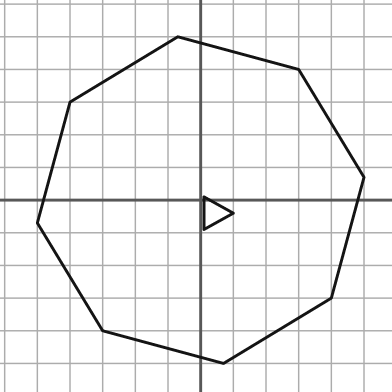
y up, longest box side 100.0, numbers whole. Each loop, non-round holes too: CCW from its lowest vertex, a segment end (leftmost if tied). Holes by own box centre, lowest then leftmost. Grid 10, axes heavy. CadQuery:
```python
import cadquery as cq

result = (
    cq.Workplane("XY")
    .moveTo(7.0, -50.0)
    .lineTo(40.0, -30.0)
    .lineTo(50.0, 7.0)
    .lineTo(30.0, 40.0)
    .lineTo(-7.0, 50.0)
    .lineTo(-40.0, 30.0)
    .lineTo(-50.0, -7.0)
    .lineTo(-30.0, -40.0)
    .close()
    .moveTo(1.0, -9.0)
    .lineTo(10.0, -4.0)
    .lineTo(1.0, 1.0)
    .close()
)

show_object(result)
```